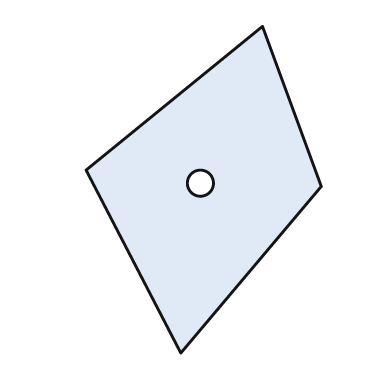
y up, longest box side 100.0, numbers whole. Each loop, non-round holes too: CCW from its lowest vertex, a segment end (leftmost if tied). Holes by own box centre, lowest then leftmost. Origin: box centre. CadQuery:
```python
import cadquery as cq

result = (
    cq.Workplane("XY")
    .moveTo(-7.0, -50.0)
    .lineTo(36.0, 1.0)
    .lineTo(18.0, 50.0)
    .lineTo(-36.0, 6.0)
    .close()
    .moveTo(-1.0, 2.0)
    .circle(4.0)
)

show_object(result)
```